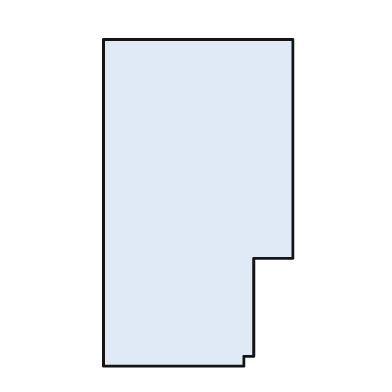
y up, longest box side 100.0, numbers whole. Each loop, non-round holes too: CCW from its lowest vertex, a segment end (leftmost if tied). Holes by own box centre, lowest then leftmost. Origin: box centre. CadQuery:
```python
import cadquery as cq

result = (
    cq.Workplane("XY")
    .moveTo(-29.0, -50.0)
    .lineTo(14.0, -50.0)
    .lineTo(14.0, -47.0)
    .lineTo(17.0, -47.0)
    .lineTo(17.0, -17.0)
    .lineTo(29.0, -17.0)
    .lineTo(29.0, 50.0)
    .lineTo(-29.0, 50.0)
    .close()
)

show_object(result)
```